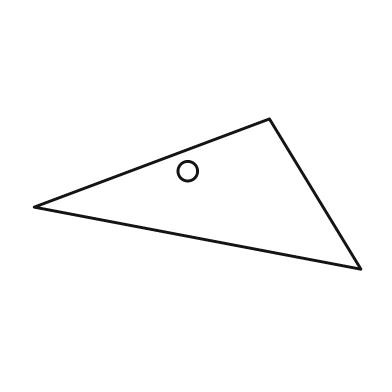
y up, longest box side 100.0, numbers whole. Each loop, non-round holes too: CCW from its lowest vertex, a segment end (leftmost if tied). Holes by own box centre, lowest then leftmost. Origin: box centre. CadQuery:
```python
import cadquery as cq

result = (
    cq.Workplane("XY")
    .moveTo(50.0, -23.0)
    .lineTo(22.0, 23.0)
    .lineTo(-50.0, -4.0)
    .close()
    .moveTo(-3.0, 7.0)
    .circle(3.0)
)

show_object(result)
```